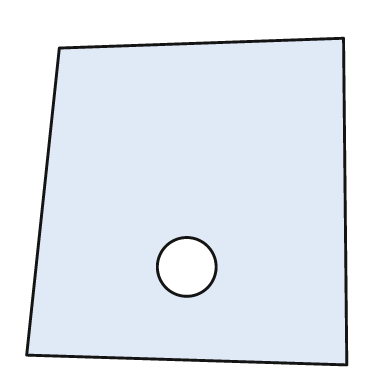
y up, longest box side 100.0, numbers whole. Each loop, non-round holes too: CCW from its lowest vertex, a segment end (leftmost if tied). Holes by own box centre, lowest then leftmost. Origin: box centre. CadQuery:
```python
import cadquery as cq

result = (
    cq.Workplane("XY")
    .moveTo(49.0, -50.0)
    .lineTo(48.0, 50.0)
    .lineTo(-39.0, 47.0)
    .lineTo(-49.0, -47.0)
    .close()
    .moveTo(0.0, -20.0)
    .circle(9.0)
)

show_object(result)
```